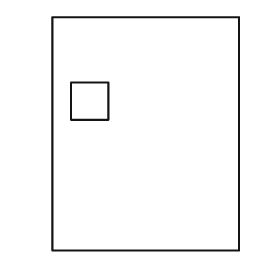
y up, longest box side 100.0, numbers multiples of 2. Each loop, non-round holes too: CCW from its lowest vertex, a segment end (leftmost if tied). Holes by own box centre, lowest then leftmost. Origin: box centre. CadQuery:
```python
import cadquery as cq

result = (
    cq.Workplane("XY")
    .moveTo(-40.0, -50.0)
    .lineTo(40.0, -50.0)
    .lineTo(40.0, 50.0)
    .lineTo(-40.0, 50.0)
    .close()
    .moveTo(-32.0, 6.0)
    .lineTo(-16.0, 6.0)
    .lineTo(-16.0, 22.0)
    .lineTo(-32.0, 22.0)
    .close()
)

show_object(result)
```